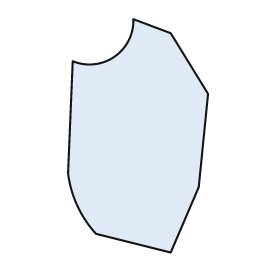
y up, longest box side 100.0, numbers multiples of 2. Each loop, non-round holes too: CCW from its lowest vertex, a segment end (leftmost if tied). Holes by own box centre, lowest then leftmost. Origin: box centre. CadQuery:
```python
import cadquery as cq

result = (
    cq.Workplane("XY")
    .moveTo(14.0, -50.0)
    .lineTo(26.0, -22.0)
    .lineTo(30.0, 18.0)
    .lineTo(14.0, 44.0)
    .lineTo(-2.0, 50.0)
    .threePointArc((-10.0, 34.0), (-28.0, 32.0))
    .lineTo(-30.0, -16.0)
    .threePointArc((-26.0, -30.0), (-18.0, -42.0))
    .close()
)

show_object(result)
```